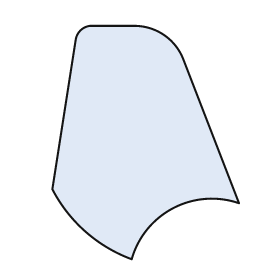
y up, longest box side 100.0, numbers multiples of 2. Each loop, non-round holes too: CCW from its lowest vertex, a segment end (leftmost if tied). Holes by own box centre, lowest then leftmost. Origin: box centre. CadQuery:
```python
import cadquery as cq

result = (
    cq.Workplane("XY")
    .moveTo(-6.0, -50.0)
    .threePointArc((12.0, -28.0), (40.0, -26.0))
    .lineTo(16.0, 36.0)
    .threePointArc((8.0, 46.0), (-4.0, 50.0))
    .lineTo(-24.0, 50.0)
    .threePointArc((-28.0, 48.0), (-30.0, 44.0))
    .lineTo(-40.0, -20.0)
    .threePointArc((-26.0, -38.0), (-6.0, -50.0))
    .close()
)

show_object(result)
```